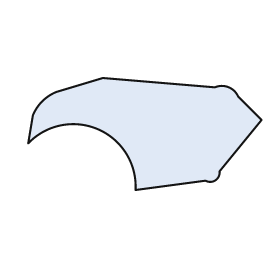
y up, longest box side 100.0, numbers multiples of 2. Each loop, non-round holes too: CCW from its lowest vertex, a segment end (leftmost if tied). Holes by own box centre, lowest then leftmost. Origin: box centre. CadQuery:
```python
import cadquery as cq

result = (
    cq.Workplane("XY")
    .moveTo(-4.0, -24.0)
    .lineTo(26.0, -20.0)
    .threePointArc((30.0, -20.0), (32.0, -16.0))
    .lineTo(50.0, 6.0)
    .lineTo(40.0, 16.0)
    .threePointArc((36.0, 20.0), (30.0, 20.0))
    .lineTo(-18.0, 24.0)
    .lineTo(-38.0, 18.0)
    .threePointArc((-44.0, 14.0), (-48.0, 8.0))
    .lineTo(-50.0, -4.0)
    .threePointArc((-20.0, 2.0), (-4.0, -24.0))
    .close()
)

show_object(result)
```